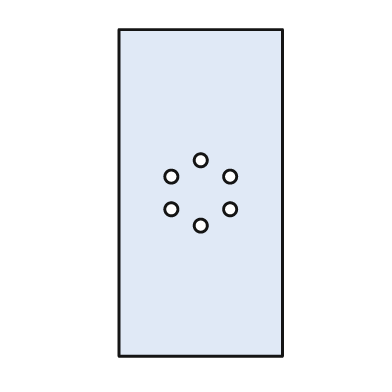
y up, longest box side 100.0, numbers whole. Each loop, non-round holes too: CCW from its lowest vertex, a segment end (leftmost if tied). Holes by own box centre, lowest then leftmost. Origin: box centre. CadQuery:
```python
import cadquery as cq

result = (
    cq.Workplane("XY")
    .moveTo(-25.0, -50.0)
    .lineTo(25.0, -50.0)
    .lineTo(25.0, 50.0)
    .lineTo(-25.0, 50.0)
    .close()
    .moveTo(0.0, -10.0)
    .circle(2.0)
    .moveTo(-9.0, -5.0)
    .circle(2.0)
    .moveTo(9.0, -5.0)
    .circle(2.0)
    .moveTo(-9.0, 5.0)
    .circle(2.0)
    .moveTo(9.0, 5.0)
    .circle(2.0)
    .moveTo(0.0, 10.0)
    .circle(2.0)
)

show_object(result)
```